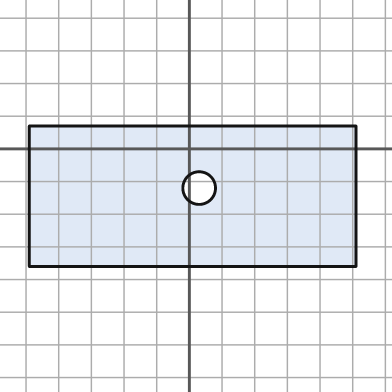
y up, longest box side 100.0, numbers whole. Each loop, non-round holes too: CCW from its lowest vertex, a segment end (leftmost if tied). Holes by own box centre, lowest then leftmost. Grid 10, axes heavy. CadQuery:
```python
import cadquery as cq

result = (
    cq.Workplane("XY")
    .moveTo(-49.0, -36.0)
    .lineTo(51.0, -36.0)
    .lineTo(51.0, 7.0)
    .lineTo(-49.0, 7.0)
    .close()
    .moveTo(3.0, -12.0)
    .circle(5.0)
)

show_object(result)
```